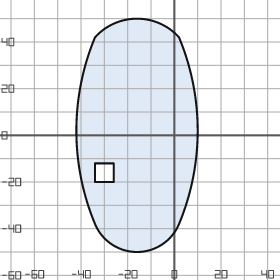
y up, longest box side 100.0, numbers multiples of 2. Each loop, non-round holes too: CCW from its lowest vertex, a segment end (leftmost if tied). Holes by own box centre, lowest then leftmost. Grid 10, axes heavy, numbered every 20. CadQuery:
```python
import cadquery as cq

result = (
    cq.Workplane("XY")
    .moveTo(-34.0, -38.0)
    .threePointArc((-16.0, -50.0), (2.0, -38.0))
    .threePointArc((10.0, 2.0), (2.0, 42.0))
    .threePointArc((-16.0, 50.0), (-34.0, 42.0))
    .threePointArc((-42.0, 2.0), (-34.0, -38.0))
    .close()
    .moveTo(-34.0, -20.0)
    .lineTo(-26.0, -20.0)
    .lineTo(-26.0, -12.0)
    .lineTo(-34.0, -12.0)
    .close()
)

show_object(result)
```